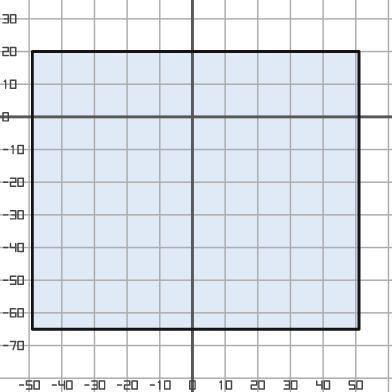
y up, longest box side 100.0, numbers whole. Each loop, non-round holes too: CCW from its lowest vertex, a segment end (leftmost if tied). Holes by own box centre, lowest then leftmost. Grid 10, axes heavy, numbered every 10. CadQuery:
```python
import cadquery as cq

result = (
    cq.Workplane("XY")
    .moveTo(-49.0, -65.0)
    .lineTo(51.0, -65.0)
    .lineTo(51.0, 20.0)
    .lineTo(-49.0, 20.0)
    .close()
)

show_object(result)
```